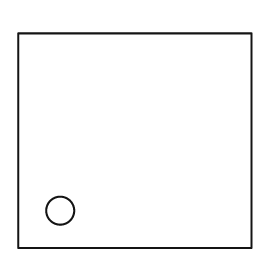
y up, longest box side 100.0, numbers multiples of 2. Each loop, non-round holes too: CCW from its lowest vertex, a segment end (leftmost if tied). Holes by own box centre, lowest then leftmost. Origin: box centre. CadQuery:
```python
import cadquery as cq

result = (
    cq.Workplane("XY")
    .moveTo(-50.0, -46.0)
    .lineTo(50.0, -46.0)
    .lineTo(50.0, 46.0)
    .lineTo(-50.0, 46.0)
    .close()
    .moveTo(-32.0, -30.0)
    .circle(6.0)
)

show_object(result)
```